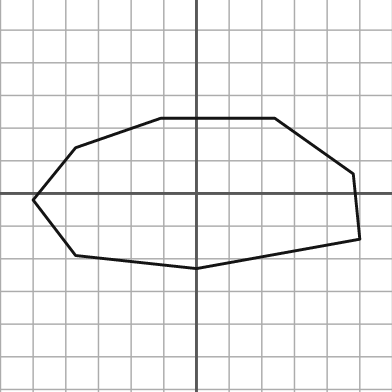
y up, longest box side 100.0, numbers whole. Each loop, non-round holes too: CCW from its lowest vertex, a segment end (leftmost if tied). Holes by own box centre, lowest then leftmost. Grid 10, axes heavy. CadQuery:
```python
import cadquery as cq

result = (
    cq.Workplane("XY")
    .moveTo(0.0, -23.0)
    .lineTo(50.0, -14.0)
    .lineTo(48.0, 6.0)
    .lineTo(24.0, 23.0)
    .lineTo(-11.0, 23.0)
    .lineTo(-37.0, 14.0)
    .lineTo(-50.0, -2.0)
    .lineTo(-37.0, -19.0)
    .close()
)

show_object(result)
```